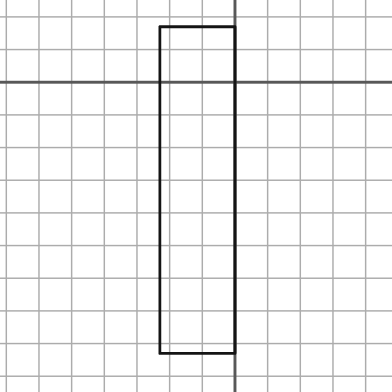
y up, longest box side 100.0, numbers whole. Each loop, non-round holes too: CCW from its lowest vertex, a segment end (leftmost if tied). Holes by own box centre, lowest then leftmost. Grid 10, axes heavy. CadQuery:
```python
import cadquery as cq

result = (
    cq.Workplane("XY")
    .moveTo(-23.0, -83.0)
    .lineTo(0.0, -83.0)
    .lineTo(0.0, 17.0)
    .lineTo(-23.0, 17.0)
    .close()
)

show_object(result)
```